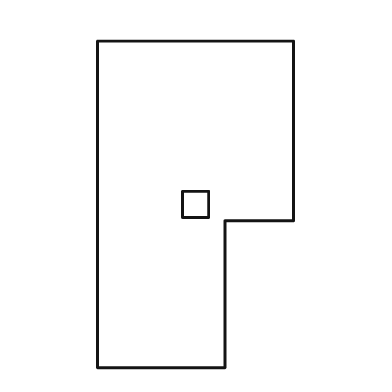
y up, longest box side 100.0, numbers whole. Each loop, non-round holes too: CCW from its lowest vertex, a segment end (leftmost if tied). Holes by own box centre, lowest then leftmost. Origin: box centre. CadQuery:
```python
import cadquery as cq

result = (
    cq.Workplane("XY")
    .moveTo(-30.0, -50.0)
    .lineTo(9.0, -50.0)
    .lineTo(9.0, -5.0)
    .lineTo(30.0, -5.0)
    .lineTo(30.0, 50.0)
    .lineTo(-30.0, 50.0)
    .close()
    .moveTo(-4.0, -4.0)
    .lineTo(4.0, -4.0)
    .lineTo(4.0, 4.0)
    .lineTo(-4.0, 4.0)
    .close()
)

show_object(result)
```